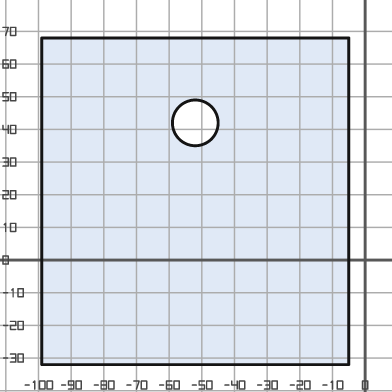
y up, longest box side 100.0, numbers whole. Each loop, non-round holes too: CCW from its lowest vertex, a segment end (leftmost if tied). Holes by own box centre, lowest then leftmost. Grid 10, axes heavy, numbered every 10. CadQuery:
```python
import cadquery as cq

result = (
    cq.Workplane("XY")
    .moveTo(-99.0, -32.0)
    .lineTo(-5.0, -32.0)
    .lineTo(-5.0, 68.0)
    .lineTo(-99.0, 68.0)
    .close()
    .moveTo(-52.0, 42.0)
    .circle(7.0)
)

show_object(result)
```